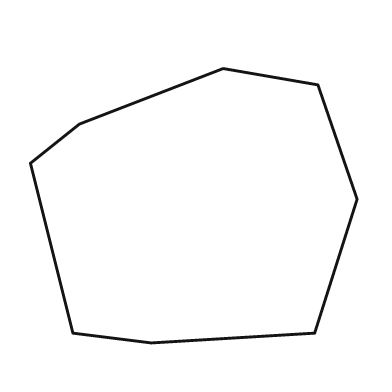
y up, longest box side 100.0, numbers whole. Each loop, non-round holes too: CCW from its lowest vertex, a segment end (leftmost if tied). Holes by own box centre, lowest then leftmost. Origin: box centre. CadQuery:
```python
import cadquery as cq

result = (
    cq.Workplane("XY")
    .moveTo(-13.0, -42.0)
    .lineTo(37.0, -39.0)
    .lineTo(50.0, 2.0)
    .lineTo(38.0, 37.0)
    .lineTo(9.0, 42.0)
    .lineTo(-35.0, 25.0)
    .lineTo(-50.0, 13.0)
    .lineTo(-37.0, -39.0)
    .close()
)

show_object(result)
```